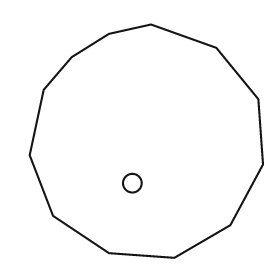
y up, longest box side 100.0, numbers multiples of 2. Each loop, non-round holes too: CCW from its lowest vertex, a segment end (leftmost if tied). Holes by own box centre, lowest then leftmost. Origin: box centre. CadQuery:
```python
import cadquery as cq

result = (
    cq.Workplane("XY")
    .moveTo(12.0, -50.0)
    .lineTo(36.0, -36.0)
    .lineTo(50.0, -10.0)
    .lineTo(48.0, 18.0)
    .lineTo(30.0, 40.0)
    .lineTo(2.0, 50.0)
    .lineTo(-16.0, 46.0)
    .lineTo(-32.0, 36.0)
    .lineTo(-44.0, 22.0)
    .lineTo(-50.0, -6.0)
    .lineTo(-40.0, -32.0)
    .lineTo(-16.0, -48.0)
    .close()
    .moveTo(-6.0, -18.0)
    .circle(4.0)
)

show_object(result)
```